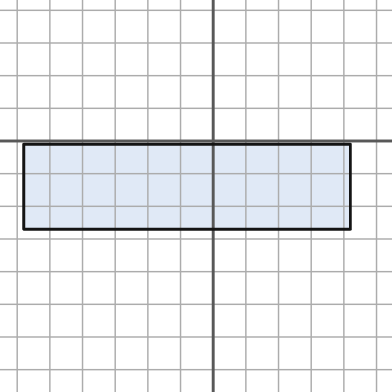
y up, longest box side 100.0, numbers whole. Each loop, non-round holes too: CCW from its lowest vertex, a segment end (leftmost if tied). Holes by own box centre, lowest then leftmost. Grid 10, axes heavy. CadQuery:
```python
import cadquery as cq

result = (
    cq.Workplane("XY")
    .moveTo(-58.0, -27.0)
    .lineTo(42.0, -27.0)
    .lineTo(42.0, -1.0)
    .lineTo(-58.0, -1.0)
    .close()
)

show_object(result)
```